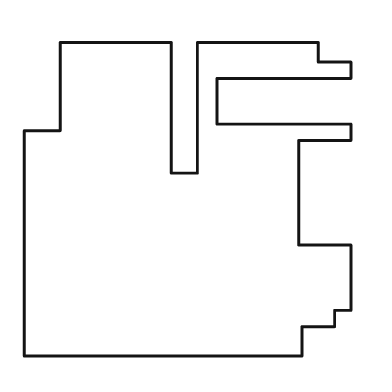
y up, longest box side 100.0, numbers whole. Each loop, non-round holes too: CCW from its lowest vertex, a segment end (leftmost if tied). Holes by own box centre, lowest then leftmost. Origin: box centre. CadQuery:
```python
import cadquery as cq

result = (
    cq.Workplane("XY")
    .moveTo(-50.0, -48.0)
    .lineTo(35.0, -48.0)
    .lineTo(35.0, -39.0)
    .lineTo(45.0, -39.0)
    .lineTo(45.0, -34.0)
    .lineTo(50.0, -34.0)
    .lineTo(50.0, -14.0)
    .lineTo(34.0, -14.0)
    .lineTo(34.0, 18.0)
    .lineTo(50.0, 18.0)
    .lineTo(50.0, 23.0)
    .lineTo(9.0, 23.0)
    .lineTo(9.0, 37.0)
    .lineTo(50.0, 37.0)
    .lineTo(50.0, 42.0)
    .lineTo(40.0, 42.0)
    .lineTo(40.0, 48.0)
    .lineTo(3.0, 48.0)
    .lineTo(3.0, 8.0)
    .lineTo(-5.0, 8.0)
    .lineTo(-5.0, 48.0)
    .lineTo(-39.0, 48.0)
    .lineTo(-39.0, 21.0)
    .lineTo(-50.0, 21.0)
    .close()
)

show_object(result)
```